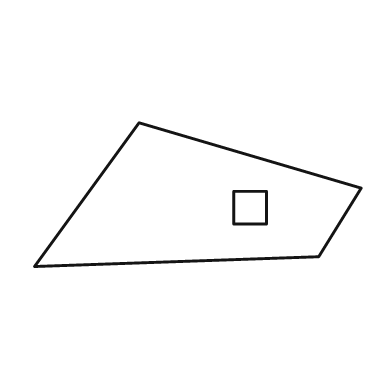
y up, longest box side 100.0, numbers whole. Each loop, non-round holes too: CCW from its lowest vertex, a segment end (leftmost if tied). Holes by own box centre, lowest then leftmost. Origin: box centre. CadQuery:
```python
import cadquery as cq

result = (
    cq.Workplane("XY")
    .moveTo(-50.0, -22.0)
    .lineTo(37.0, -19.0)
    .lineTo(50.0, 2.0)
    .lineTo(-18.0, 22.0)
    .close()
    .moveTo(11.0, -9.0)
    .lineTo(21.0, -9.0)
    .lineTo(21.0, 1.0)
    .lineTo(11.0, 1.0)
    .close()
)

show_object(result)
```